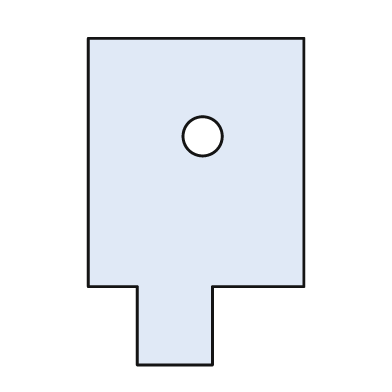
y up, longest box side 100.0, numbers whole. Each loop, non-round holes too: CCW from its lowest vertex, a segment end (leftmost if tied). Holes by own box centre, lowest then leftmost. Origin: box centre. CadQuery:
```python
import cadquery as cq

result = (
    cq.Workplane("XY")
    .moveTo(-18.0, -50.0)
    .lineTo(5.0, -50.0)
    .lineTo(5.0, -26.0)
    .lineTo(33.0, -26.0)
    .lineTo(33.0, 50.0)
    .lineTo(-33.0, 50.0)
    .lineTo(-33.0, -26.0)
    .lineTo(-18.0, -26.0)
    .close()
    .moveTo(2.0, 20.0)
    .circle(6.0)
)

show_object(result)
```